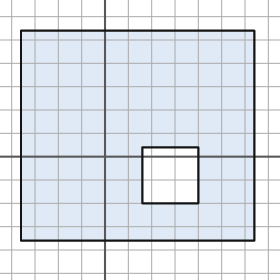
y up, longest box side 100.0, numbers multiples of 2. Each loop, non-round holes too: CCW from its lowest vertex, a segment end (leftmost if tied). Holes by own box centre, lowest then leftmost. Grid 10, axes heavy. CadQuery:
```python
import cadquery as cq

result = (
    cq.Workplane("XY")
    .moveTo(-36.0, -36.0)
    .lineTo(64.0, -36.0)
    .lineTo(64.0, 54.0)
    .lineTo(-36.0, 54.0)
    .close()
    .moveTo(16.0, -20.0)
    .lineTo(40.0, -20.0)
    .lineTo(40.0, 4.0)
    .lineTo(16.0, 4.0)
    .close()
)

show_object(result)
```